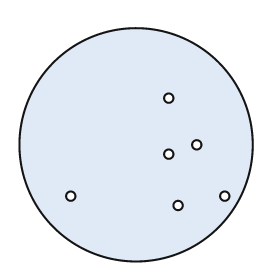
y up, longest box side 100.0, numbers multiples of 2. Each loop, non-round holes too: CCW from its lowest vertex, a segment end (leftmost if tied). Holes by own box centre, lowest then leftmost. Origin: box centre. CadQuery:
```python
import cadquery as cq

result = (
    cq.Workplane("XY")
    .moveTo(0.0, 0.0)
    .circle(50.0)
    .moveTo(18.0, -26.0)
    .circle(2.0)
    .moveTo(-28.0, -22.0)
    .circle(2.0)
    .moveTo(38.0, -22.0)
    .circle(2.0)
    .moveTo(14.0, -4.0)
    .circle(2.0)
    .moveTo(26.0, 0.0)
    .circle(2.0)
    .moveTo(14.0, 20.0)
    .circle(2.0)
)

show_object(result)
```